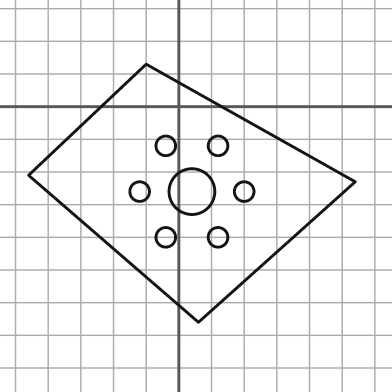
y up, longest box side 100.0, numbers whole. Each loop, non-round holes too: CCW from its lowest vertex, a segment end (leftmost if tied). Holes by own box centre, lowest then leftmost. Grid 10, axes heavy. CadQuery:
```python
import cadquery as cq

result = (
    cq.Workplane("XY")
    .moveTo(6.0, -66.0)
    .lineTo(54.0, -23.0)
    .lineTo(-10.0, 13.0)
    .lineTo(-46.0, -21.0)
    .close()
    .moveTo(-4.0, -40.0)
    .circle(3.0)
    .moveTo(12.0, -40.0)
    .circle(3.0)
    .moveTo(-12.0, -26.0)
    .circle(3.0)
    .moveTo(4.0, -26.0)
    .circle(7.0)
    .moveTo(20.0, -26.0)
    .circle(3.0)
    .moveTo(-4.0, -12.0)
    .circle(3.0)
    .moveTo(12.0, -12.0)
    .circle(3.0)
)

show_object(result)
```